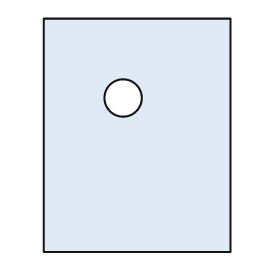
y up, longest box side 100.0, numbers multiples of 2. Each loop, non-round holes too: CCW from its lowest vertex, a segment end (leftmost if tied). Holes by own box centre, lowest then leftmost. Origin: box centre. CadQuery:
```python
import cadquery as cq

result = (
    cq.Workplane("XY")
    .moveTo(-40.0, -50.0)
    .lineTo(40.0, -50.0)
    .lineTo(40.0, 50.0)
    .lineTo(-40.0, 50.0)
    .close()
    .moveTo(-6.0, 16.0)
    .circle(8.0)
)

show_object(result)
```